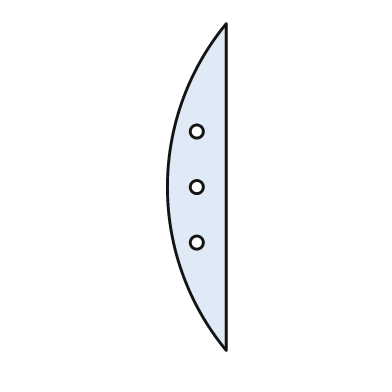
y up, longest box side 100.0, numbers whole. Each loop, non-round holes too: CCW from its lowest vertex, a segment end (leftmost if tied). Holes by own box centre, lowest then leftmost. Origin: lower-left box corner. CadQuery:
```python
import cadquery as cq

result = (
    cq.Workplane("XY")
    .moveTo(18.0, 0.0)
    .lineTo(18.0, 100.0)
    .threePointArc((0.0, 50.0), (18.0, 0.0))
    .close()
    .moveTo(9.0, 33.0)
    .circle(2.0)
    .moveTo(9.0, 50.0)
    .circle(2.0)
    .moveTo(9.0, 67.0)
    .circle(2.0)
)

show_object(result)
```